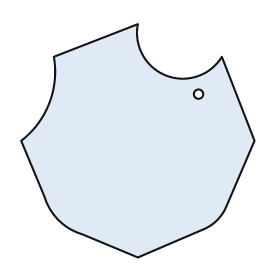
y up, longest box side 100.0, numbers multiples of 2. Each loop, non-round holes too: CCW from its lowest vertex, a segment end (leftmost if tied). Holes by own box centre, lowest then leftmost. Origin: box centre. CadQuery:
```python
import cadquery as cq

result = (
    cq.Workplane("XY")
    .moveTo(0.0, -50.0)
    .lineTo(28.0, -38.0)
    .threePointArc((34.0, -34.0), (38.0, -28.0))
    .lineTo(50.0, 0.0)
    .lineTo(36.0, 36.0)
    .threePointArc((12.0, 28.0), (0.0, 50.0))
    .lineTo(-36.0, 36.0)
    .threePointArc((-38.0, 16.0), (-50.0, 0.0))
    .lineTo(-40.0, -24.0)
    .threePointArc((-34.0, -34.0), (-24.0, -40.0))
    .close()
    .moveTo(26.0, 20.0)
    .circle(2.0)
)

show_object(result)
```